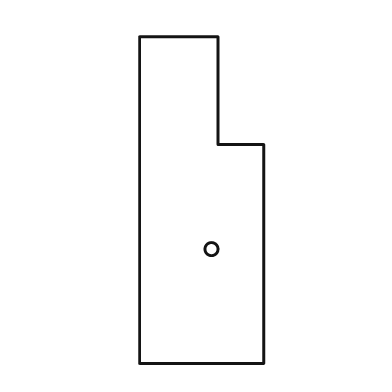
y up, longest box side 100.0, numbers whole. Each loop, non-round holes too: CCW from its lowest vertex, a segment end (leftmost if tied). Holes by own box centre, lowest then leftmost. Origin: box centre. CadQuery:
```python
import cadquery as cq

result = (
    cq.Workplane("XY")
    .moveTo(-19.0, -50.0)
    .lineTo(19.0, -50.0)
    .lineTo(19.0, 17.0)
    .lineTo(5.0, 17.0)
    .lineTo(5.0, 50.0)
    .lineTo(-19.0, 50.0)
    .close()
    .moveTo(3.0, -15.0)
    .circle(2.0)
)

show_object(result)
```